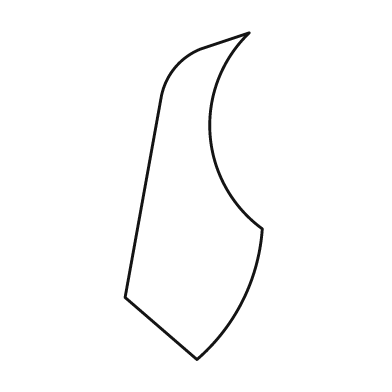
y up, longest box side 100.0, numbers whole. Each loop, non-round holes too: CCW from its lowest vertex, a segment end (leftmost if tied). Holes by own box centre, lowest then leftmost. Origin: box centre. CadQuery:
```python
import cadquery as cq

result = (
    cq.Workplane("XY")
    .moveTo(1.0, -50.0)
    .threePointArc((15.0, -32.0), (21.0, -10.0))
    .threePointArc((5.0, 19.0), (17.0, 50.0))
    .lineTo(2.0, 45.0)
    .threePointArc((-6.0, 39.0), (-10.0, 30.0))
    .lineTo(-21.0, -31.0)
    .close()
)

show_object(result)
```